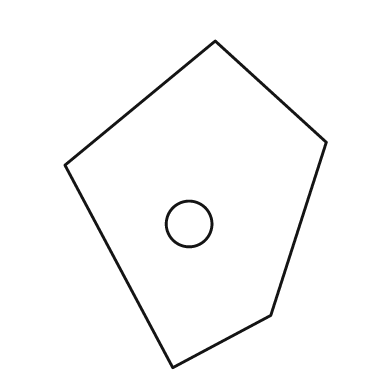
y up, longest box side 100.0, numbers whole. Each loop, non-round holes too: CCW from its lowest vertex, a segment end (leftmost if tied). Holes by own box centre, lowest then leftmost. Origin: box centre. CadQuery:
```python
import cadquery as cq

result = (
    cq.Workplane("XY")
    .moveTo(-7.0, -50.0)
    .lineTo(23.0, -34.0)
    .lineTo(40.0, 19.0)
    .lineTo(6.0, 50.0)
    .lineTo(-40.0, 12.0)
    .close()
    .moveTo(-2.0, -6.0)
    .circle(7.0)
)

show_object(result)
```